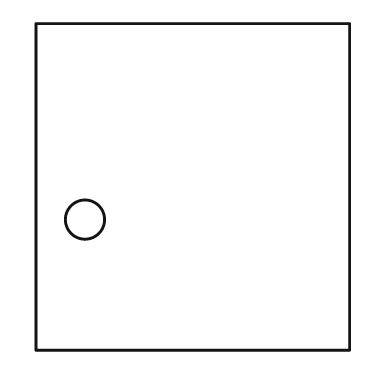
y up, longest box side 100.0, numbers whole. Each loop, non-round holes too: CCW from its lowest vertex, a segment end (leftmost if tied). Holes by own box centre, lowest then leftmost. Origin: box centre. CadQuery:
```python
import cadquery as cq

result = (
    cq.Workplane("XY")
    .moveTo(-48.0, -50.0)
    .lineTo(48.0, -50.0)
    .lineTo(48.0, 50.0)
    .lineTo(-48.0, 50.0)
    .close()
    .moveTo(-33.0, -10.0)
    .circle(6.0)
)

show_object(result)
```